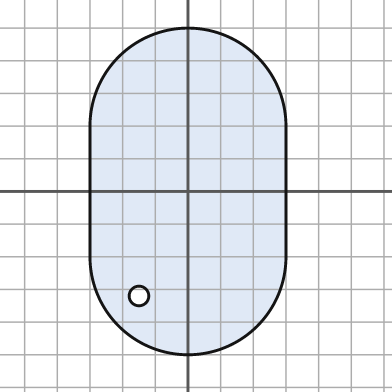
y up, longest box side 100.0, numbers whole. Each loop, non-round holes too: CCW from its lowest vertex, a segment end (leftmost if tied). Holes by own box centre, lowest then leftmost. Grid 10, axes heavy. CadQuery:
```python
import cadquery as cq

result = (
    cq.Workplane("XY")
    .moveTo(-30.0, -20.0)
    .threePointArc((0.0, -50.0), (30.0, -20.0))
    .lineTo(30.0, 20.0)
    .threePointArc((0.0, 50.0), (-30.0, 20.0))
    .close()
    .moveTo(-15.0, -32.0)
    .circle(3.0)
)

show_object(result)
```